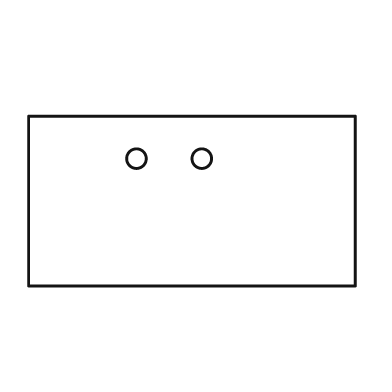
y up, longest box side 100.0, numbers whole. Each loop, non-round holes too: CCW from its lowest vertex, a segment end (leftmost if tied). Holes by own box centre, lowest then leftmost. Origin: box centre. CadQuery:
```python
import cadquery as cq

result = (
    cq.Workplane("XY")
    .moveTo(-50.0, -26.0)
    .lineTo(50.0, -26.0)
    .lineTo(50.0, 26.0)
    .lineTo(-50.0, 26.0)
    .close()
    .moveTo(-17.0, 13.0)
    .circle(3.0)
    .moveTo(3.0, 13.0)
    .circle(3.0)
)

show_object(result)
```